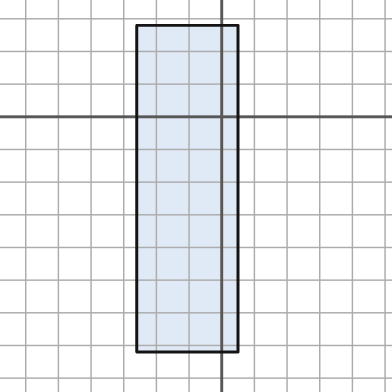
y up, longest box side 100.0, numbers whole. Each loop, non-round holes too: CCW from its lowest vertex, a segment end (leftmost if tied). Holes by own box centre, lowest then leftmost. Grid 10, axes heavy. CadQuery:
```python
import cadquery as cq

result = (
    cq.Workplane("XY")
    .moveTo(-26.0, -72.0)
    .lineTo(5.0, -72.0)
    .lineTo(5.0, 28.0)
    .lineTo(-26.0, 28.0)
    .close()
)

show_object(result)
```